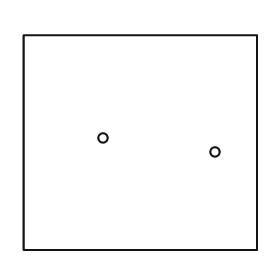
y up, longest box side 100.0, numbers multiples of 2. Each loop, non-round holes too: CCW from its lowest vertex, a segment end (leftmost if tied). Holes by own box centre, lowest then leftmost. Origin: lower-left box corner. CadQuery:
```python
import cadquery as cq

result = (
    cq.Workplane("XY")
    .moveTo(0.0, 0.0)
    .lineTo(100.0, 0.0)
    .lineTo(100.0, 92.0)
    .lineTo(0.0, 92.0)
    .close()
    .moveTo(82.0, 42.0)
    .circle(2.0)
    .moveTo(34.0, 48.0)
    .circle(2.0)
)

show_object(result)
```